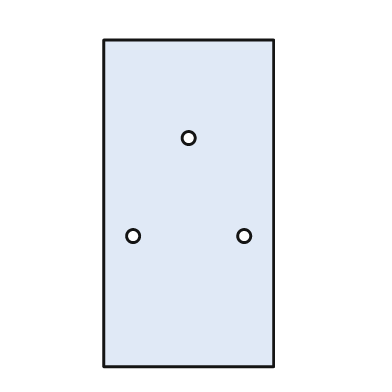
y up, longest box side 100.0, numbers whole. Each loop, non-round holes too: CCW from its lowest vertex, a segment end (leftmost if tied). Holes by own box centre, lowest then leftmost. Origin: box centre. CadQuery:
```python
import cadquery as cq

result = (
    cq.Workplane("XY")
    .moveTo(-26.0, -50.0)
    .lineTo(26.0, -50.0)
    .lineTo(26.0, 50.0)
    .lineTo(-26.0, 50.0)
    .close()
    .moveTo(-17.0, -10.0)
    .circle(2.0)
    .moveTo(17.0, -10.0)
    .circle(2.0)
    .moveTo(0.0, 20.0)
    .circle(2.0)
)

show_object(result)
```